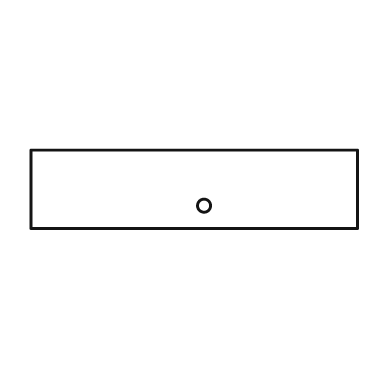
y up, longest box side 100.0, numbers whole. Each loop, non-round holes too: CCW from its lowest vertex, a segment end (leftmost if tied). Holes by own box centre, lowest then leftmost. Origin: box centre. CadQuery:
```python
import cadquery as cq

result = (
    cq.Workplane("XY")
    .moveTo(-50.0, -12.0)
    .lineTo(50.0, -12.0)
    .lineTo(50.0, 12.0)
    .lineTo(-50.0, 12.0)
    .close()
    .moveTo(3.0, -5.0)
    .circle(2.0)
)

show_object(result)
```